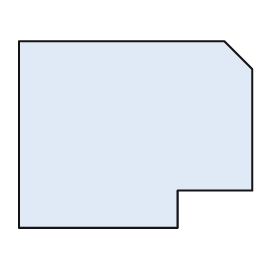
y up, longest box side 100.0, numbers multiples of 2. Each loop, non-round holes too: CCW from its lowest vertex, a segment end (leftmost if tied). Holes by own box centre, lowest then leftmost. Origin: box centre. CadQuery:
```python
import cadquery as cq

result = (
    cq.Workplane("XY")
    .moveTo(-50.0, -40.0)
    .lineTo(18.0, -40.0)
    .lineTo(18.0, -24.0)
    .lineTo(50.0, -24.0)
    .lineTo(50.0, 28.0)
    .lineTo(38.0, 40.0)
    .lineTo(-50.0, 40.0)
    .close()
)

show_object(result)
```